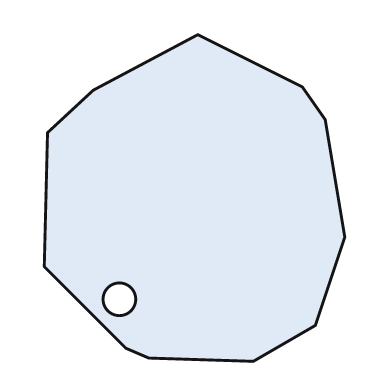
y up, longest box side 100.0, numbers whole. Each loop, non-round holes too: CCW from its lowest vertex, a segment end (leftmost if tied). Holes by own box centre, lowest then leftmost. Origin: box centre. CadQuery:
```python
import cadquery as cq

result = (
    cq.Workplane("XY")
    .moveTo(18.0, -50.0)
    .lineTo(37.0, -39.0)
    .lineTo(46.0, -12.0)
    .lineTo(40.0, 24.0)
    .lineTo(33.0, 34.0)
    .lineTo(1.0, 50.0)
    .lineTo(-31.0, 33.0)
    .lineTo(-45.0, 20.0)
    .lineTo(-46.0, -21.0)
    .lineTo(-21.0, -46.0)
    .lineTo(-14.0, -49.0)
    .close()
    .moveTo(-23.0, -31.0)
    .circle(5.0)
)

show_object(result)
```